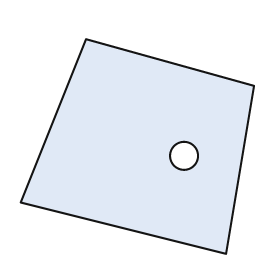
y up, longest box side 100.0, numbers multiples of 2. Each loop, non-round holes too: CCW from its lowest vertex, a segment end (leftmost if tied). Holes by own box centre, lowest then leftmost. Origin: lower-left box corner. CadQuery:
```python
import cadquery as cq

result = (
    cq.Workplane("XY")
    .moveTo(88.0, 0.0)
    .lineTo(100.0, 72.0)
    .lineTo(28.0, 92.0)
    .lineTo(0.0, 22.0)
    .close()
    .moveTo(70.0, 42.0)
    .circle(6.0)
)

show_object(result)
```